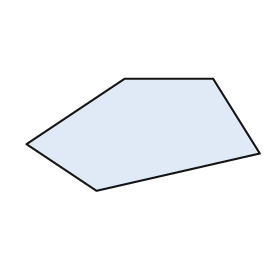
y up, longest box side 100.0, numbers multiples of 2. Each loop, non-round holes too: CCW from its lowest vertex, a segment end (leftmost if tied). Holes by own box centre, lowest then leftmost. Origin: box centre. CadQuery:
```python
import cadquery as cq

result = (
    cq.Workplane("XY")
    .moveTo(-20.0, -24.0)
    .lineTo(50.0, -8.0)
    .lineTo(30.0, 24.0)
    .lineTo(-8.0, 24.0)
    .lineTo(-50.0, -4.0)
    .close()
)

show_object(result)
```